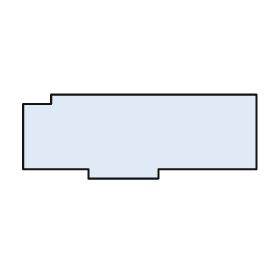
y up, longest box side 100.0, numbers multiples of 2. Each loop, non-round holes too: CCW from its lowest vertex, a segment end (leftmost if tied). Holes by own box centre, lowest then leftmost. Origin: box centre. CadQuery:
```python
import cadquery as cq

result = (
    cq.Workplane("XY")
    .moveTo(-22.0, -18.0)
    .lineTo(8.0, -18.0)
    .lineTo(8.0, -14.0)
    .lineTo(50.0, -14.0)
    .lineTo(50.0, 18.0)
    .lineTo(-38.0, 18.0)
    .lineTo(-38.0, 14.0)
    .lineTo(-50.0, 14.0)
    .lineTo(-50.0, -14.0)
    .lineTo(-22.0, -14.0)
    .close()
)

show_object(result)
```